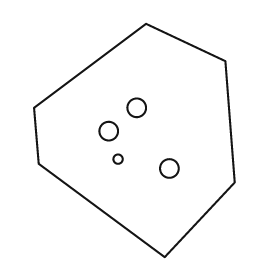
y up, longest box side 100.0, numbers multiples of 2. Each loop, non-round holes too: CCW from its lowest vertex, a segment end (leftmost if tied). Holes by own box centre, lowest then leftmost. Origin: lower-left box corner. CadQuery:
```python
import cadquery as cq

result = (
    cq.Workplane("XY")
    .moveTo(56.0, 0.0)
    .lineTo(86.0, 32.0)
    .lineTo(82.0, 84.0)
    .lineTo(48.0, 100.0)
    .lineTo(0.0, 64.0)
    .lineTo(2.0, 40.0)
    .close()
    .moveTo(58.0, 38.0)
    .circle(4.0)
    .moveTo(36.0, 42.0)
    .circle(2.0)
    .moveTo(32.0, 54.0)
    .circle(4.0)
    .moveTo(44.0, 64.0)
    .circle(4.0)
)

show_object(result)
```